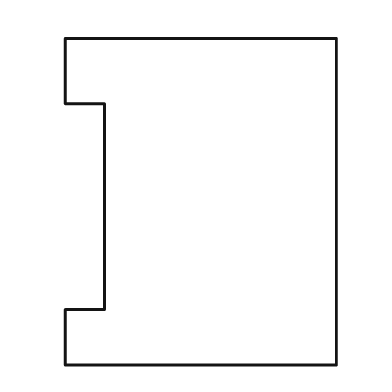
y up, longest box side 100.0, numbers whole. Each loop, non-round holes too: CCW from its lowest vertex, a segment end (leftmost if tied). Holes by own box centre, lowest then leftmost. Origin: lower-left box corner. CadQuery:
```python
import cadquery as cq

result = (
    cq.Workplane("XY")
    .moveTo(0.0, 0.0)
    .lineTo(83.0, 0.0)
    .lineTo(83.0, 100.0)
    .lineTo(0.0, 100.0)
    .lineTo(0.0, 80.0)
    .lineTo(12.0, 80.0)
    .lineTo(12.0, 17.0)
    .lineTo(0.0, 17.0)
    .close()
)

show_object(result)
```